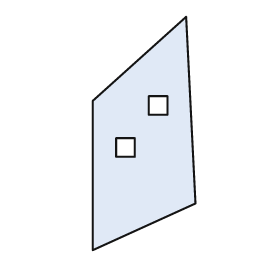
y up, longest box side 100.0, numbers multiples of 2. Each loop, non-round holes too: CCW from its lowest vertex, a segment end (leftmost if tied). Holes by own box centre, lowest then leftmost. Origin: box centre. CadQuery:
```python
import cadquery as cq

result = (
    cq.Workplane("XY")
    .moveTo(-22.0, -50.0)
    .lineTo(22.0, -30.0)
    .lineTo(18.0, 50.0)
    .lineTo(-22.0, 14.0)
    .close()
    .moveTo(-12.0, -10.0)
    .lineTo(-4.0, -10.0)
    .lineTo(-4.0, -2.0)
    .lineTo(-12.0, -2.0)
    .close()
    .moveTo(2.0, 8.0)
    .lineTo(10.0, 8.0)
    .lineTo(10.0, 16.0)
    .lineTo(2.0, 16.0)
    .close()
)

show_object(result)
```